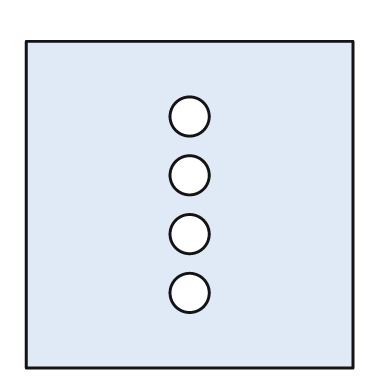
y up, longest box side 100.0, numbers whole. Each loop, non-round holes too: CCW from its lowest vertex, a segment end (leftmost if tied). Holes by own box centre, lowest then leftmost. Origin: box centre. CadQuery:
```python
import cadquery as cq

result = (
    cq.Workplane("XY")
    .moveTo(-50.0, -50.0)
    .lineTo(50.0, -50.0)
    .lineTo(50.0, 50.0)
    .lineTo(-50.0, 50.0)
    .close()
    .moveTo(0.0, -27.0)
    .circle(6.0)
    .moveTo(0.0, -9.0)
    .circle(6.0)
    .moveTo(0.0, 9.0)
    .circle(6.0)
    .moveTo(0.0, 27.0)
    .circle(6.0)
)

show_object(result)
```